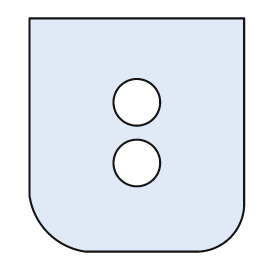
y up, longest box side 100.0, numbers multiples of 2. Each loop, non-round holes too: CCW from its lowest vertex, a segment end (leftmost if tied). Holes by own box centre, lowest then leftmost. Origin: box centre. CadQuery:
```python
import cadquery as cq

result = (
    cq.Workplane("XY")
    .moveTo(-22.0, -50.0)
    .lineTo(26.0, -50.0)
    .threePointArc((40.0, -44.0), (46.0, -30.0))
    .lineTo(46.0, 50.0)
    .lineTo(-46.0, 50.0)
    .lineTo(-46.0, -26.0)
    .threePointArc((-38.0, -42.0), (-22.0, -50.0))
    .close()
    .moveTo(0.0, -12.0)
    .circle(10.0)
    .moveTo(0.0, 14.0)
    .circle(10.0)
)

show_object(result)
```